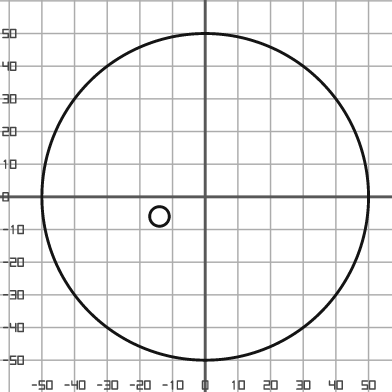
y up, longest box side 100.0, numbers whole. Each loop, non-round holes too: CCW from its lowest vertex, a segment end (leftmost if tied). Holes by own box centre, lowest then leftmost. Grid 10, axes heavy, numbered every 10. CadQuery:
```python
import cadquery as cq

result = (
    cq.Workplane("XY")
    .moveTo(0.0, 0.0)
    .circle(50.0)
    .moveTo(-14.0, -6.0)
    .circle(3.0)
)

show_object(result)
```